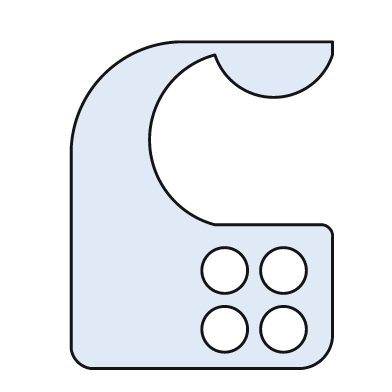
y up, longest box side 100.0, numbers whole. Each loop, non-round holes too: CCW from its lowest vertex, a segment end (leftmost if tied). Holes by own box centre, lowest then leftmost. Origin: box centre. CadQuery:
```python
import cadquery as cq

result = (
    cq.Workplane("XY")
    .moveTo(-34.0, -50.0)
    .lineTo(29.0, -50.0)
    .threePointArc((37.0, -47.0), (40.0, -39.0))
    .lineTo(40.0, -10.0)
    .threePointArc((39.0, -7.0), (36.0, -6.0))
    .lineTo(4.0, -6.0)
    .threePointArc((-16.0, 20.0), (4.0, 46.0))
    .threePointArc((22.0, 33.0), (40.0, 46.0))
    .lineTo(40.0, 50.0)
    .lineTo(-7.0, 50.0)
    .threePointArc((-30.0, 40.0), (-40.0, 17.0))
    .lineTo(-40.0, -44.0)
    .threePointArc((-38.0, -48.0), (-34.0, -50.0))
    .close()
    .moveTo(7.0, -38.0)
    .circle(7.0)
    .moveTo(25.0, -38.0)
    .circle(7.0)
    .moveTo(7.0, -20.0)
    .circle(7.0)
    .moveTo(25.0, -20.0)
    .circle(7.0)
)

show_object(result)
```